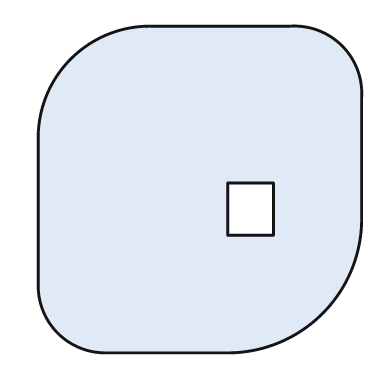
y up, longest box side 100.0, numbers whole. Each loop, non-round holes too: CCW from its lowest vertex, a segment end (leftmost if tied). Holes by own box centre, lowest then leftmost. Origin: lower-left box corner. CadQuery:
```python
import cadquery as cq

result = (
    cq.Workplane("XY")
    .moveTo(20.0, 0.0)
    .lineTo(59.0, 0.0)
    .threePointArc((87.0, 12.0), (99.0, 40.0))
    .lineTo(99.0, 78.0)
    .threePointArc((93.0, 94.0), (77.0, 100.0))
    .lineTo(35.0, 100.0)
    .threePointArc((10.0, 90.0), (0.0, 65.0))
    .lineTo(0.0, 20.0)
    .threePointArc((6.0, 6.0), (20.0, 0.0))
    .close()
    .moveTo(58.0, 36.0)
    .lineTo(72.0, 36.0)
    .lineTo(72.0, 52.0)
    .lineTo(58.0, 52.0)
    .close()
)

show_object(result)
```